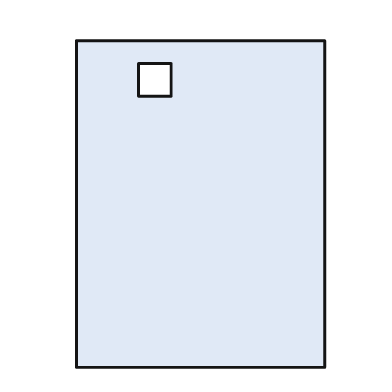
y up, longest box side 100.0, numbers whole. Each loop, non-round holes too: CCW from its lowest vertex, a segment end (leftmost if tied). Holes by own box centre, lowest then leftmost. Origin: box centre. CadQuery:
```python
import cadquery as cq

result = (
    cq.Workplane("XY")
    .moveTo(-38.0, -50.0)
    .lineTo(38.0, -50.0)
    .lineTo(38.0, 50.0)
    .lineTo(-38.0, 50.0)
    .close()
    .moveTo(-19.0, 33.0)
    .lineTo(-9.0, 33.0)
    .lineTo(-9.0, 43.0)
    .lineTo(-19.0, 43.0)
    .close()
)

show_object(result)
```